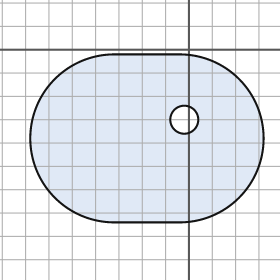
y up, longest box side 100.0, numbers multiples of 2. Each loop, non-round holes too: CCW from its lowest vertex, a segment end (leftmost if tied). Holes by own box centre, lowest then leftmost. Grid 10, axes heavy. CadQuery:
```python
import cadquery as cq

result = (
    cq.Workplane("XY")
    .moveTo(-32.0, -74.0)
    .lineTo(-4.0, -74.0)
    .threePointArc((32.0, -38.0), (-4.0, -2.0))
    .lineTo(-32.0, -2.0)
    .threePointArc((-68.0, -38.0), (-32.0, -74.0))
    .close()
    .moveTo(-2.0, -30.0)
    .circle(6.0)
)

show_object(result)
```